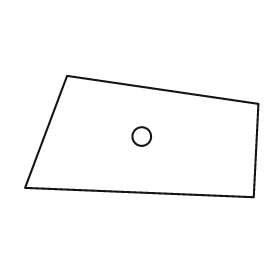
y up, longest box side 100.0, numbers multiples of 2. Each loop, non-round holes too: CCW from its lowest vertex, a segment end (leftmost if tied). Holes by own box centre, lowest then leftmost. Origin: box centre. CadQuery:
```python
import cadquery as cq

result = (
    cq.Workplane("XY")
    .moveTo(48.0, -26.0)
    .lineTo(50.0, 14.0)
    .lineTo(-32.0, 26.0)
    .lineTo(-50.0, -22.0)
    .close()
    .moveTo(0.0, 0.0)
    .circle(4.0)
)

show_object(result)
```